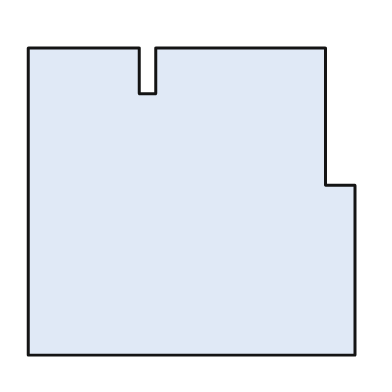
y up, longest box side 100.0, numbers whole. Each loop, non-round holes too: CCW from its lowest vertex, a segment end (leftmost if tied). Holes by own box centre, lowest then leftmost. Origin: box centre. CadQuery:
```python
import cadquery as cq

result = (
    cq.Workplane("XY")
    .moveTo(-50.0, -47.0)
    .lineTo(50.0, -47.0)
    .lineTo(50.0, 5.0)
    .lineTo(41.0, 5.0)
    .lineTo(41.0, 47.0)
    .lineTo(-11.0, 47.0)
    .lineTo(-11.0, 33.0)
    .lineTo(-16.0, 33.0)
    .lineTo(-16.0, 47.0)
    .lineTo(-50.0, 47.0)
    .close()
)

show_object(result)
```